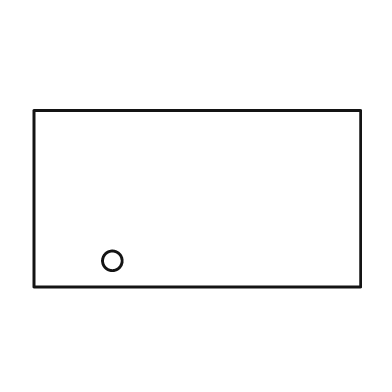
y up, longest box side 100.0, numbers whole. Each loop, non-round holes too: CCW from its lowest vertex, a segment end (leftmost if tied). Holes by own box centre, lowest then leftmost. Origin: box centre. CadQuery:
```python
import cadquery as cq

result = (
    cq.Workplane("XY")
    .moveTo(-50.0, -27.0)
    .lineTo(50.0, -27.0)
    .lineTo(50.0, 27.0)
    .lineTo(-50.0, 27.0)
    .close()
    .moveTo(-26.0, -19.0)
    .circle(3.0)
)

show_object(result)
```